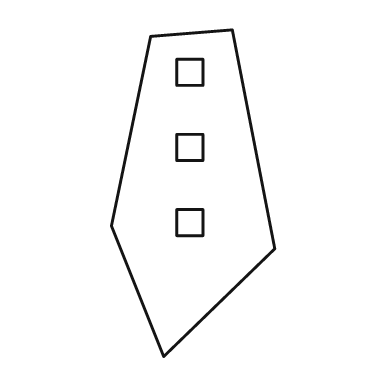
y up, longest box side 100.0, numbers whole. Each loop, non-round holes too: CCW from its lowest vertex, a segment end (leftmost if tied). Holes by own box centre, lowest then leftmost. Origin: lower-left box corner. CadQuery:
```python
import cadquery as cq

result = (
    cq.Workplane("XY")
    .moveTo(16.0, 0.0)
    .lineTo(50.0, 33.0)
    .lineTo(37.0, 100.0)
    .lineTo(12.0, 98.0)
    .lineTo(0.0, 40.0)
    .close()
    .moveTo(20.0, 37.0)
    .lineTo(28.0, 37.0)
    .lineTo(28.0, 45.0)
    .lineTo(20.0, 45.0)
    .close()
    .moveTo(20.0, 60.0)
    .lineTo(28.0, 60.0)
    .lineTo(28.0, 68.0)
    .lineTo(20.0, 68.0)
    .close()
    .moveTo(20.0, 83.0)
    .lineTo(28.0, 83.0)
    .lineTo(28.0, 91.0)
    .lineTo(20.0, 91.0)
    .close()
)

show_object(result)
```